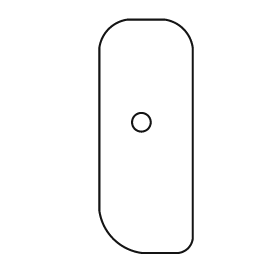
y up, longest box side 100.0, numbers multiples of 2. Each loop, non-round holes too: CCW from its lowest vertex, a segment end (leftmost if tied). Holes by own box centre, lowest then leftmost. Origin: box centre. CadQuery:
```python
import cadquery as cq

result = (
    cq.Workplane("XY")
    .moveTo(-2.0, -50.0)
    .lineTo(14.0, -50.0)
    .threePointArc((18.0, -48.0), (20.0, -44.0))
    .lineTo(20.0, 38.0)
    .threePointArc((16.0, 46.0), (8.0, 50.0))
    .lineTo(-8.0, 50.0)
    .threePointArc((-16.0, 46.0), (-20.0, 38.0))
    .lineTo(-20.0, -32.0)
    .threePointArc((-14.0, -44.0), (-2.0, -50.0))
    .close()
    .moveTo(-2.0, 6.0)
    .circle(4.0)
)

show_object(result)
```